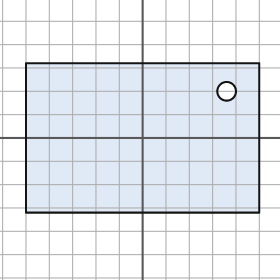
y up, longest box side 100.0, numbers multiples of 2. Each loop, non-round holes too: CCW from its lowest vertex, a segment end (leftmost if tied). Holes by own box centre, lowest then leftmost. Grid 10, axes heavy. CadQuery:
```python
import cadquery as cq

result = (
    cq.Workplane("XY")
    .moveTo(-50.0, -32.0)
    .lineTo(50.0, -32.0)
    .lineTo(50.0, 32.0)
    .lineTo(-50.0, 32.0)
    .close()
    .moveTo(36.0, 20.0)
    .circle(4.0)
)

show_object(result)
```